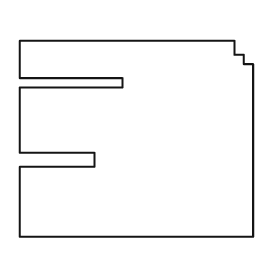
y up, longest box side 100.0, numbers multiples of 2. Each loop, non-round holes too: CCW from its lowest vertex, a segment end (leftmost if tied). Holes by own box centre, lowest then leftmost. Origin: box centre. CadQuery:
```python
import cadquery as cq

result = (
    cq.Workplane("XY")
    .moveTo(-50.0, -42.0)
    .lineTo(50.0, -42.0)
    .lineTo(50.0, 32.0)
    .lineTo(46.0, 32.0)
    .lineTo(46.0, 36.0)
    .lineTo(42.0, 36.0)
    .lineTo(42.0, 42.0)
    .lineTo(-50.0, 42.0)
    .lineTo(-50.0, 26.0)
    .lineTo(-6.0, 26.0)
    .lineTo(-6.0, 22.0)
    .lineTo(-50.0, 22.0)
    .lineTo(-50.0, -6.0)
    .lineTo(-18.0, -6.0)
    .lineTo(-18.0, -12.0)
    .lineTo(-50.0, -12.0)
    .close()
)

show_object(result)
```